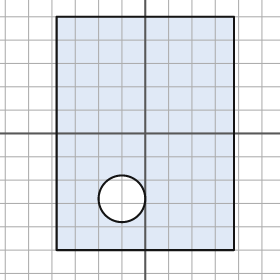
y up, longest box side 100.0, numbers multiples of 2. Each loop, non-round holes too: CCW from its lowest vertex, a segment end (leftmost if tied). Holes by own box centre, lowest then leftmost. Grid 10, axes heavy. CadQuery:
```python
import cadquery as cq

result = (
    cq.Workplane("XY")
    .moveTo(-38.0, -50.0)
    .lineTo(38.0, -50.0)
    .lineTo(38.0, 50.0)
    .lineTo(-38.0, 50.0)
    .close()
    .moveTo(-10.0, -28.0)
    .circle(10.0)
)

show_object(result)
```